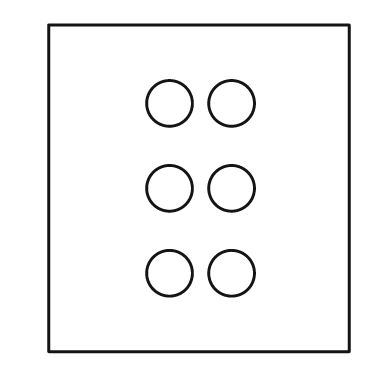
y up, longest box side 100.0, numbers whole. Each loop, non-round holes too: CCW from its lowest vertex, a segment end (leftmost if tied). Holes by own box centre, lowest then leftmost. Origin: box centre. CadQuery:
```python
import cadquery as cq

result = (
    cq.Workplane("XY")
    .moveTo(-46.0, -50.0)
    .lineTo(46.0, -50.0)
    .lineTo(46.0, 50.0)
    .lineTo(-46.0, 50.0)
    .close()
    .moveTo(-9.0, -26.0)
    .circle(7.0)
    .moveTo(10.0, -26.0)
    .circle(7.0)
    .moveTo(-9.0, 0.0)
    .circle(7.0)
    .moveTo(10.0, 0.0)
    .circle(7.0)
    .moveTo(-9.0, 26.0)
    .circle(7.0)
    .moveTo(10.0, 26.0)
    .circle(7.0)
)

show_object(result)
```